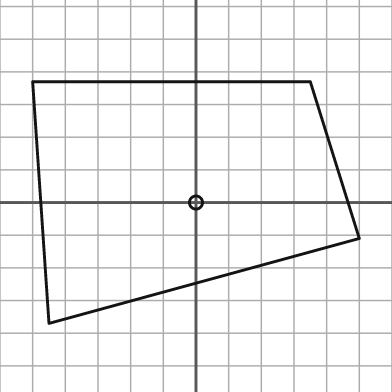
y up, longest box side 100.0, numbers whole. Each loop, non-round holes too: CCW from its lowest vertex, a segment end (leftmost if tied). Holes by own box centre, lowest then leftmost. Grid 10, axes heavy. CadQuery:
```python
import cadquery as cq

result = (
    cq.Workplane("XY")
    .moveTo(-45.0, -37.0)
    .lineTo(50.0, -11.0)
    .lineTo(35.0, 37.0)
    .lineTo(-50.0, 37.0)
    .close()
    .moveTo(0.0, 0.0)
    .circle(2.0)
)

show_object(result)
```